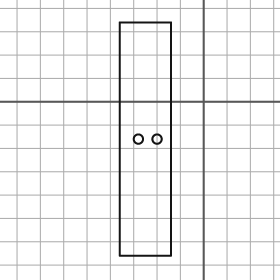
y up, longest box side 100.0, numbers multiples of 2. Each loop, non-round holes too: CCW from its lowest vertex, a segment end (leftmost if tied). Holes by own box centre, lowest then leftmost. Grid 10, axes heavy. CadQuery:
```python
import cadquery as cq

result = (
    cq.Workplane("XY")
    .moveTo(-36.0, -66.0)
    .lineTo(-14.0, -66.0)
    .lineTo(-14.0, 34.0)
    .lineTo(-36.0, 34.0)
    .close()
    .moveTo(-28.0, -16.0)
    .circle(2.0)
    .moveTo(-20.0, -16.0)
    .circle(2.0)
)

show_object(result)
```